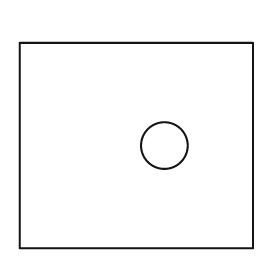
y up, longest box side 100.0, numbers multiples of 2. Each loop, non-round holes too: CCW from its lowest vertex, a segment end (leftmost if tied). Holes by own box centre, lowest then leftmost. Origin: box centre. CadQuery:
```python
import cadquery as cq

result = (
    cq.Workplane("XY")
    .moveTo(-50.0, -44.0)
    .lineTo(50.0, -44.0)
    .lineTo(50.0, 44.0)
    .lineTo(-50.0, 44.0)
    .close()
    .moveTo(12.0, 0.0)
    .circle(10.0)
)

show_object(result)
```